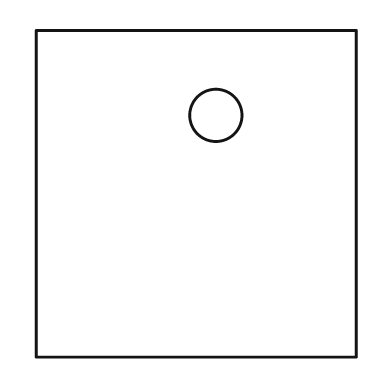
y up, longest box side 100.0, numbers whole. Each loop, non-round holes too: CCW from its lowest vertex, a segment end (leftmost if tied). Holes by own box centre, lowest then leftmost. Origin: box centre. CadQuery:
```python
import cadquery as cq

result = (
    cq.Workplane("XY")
    .moveTo(-49.0, -50.0)
    .lineTo(49.0, -50.0)
    .lineTo(49.0, 50.0)
    .lineTo(-49.0, 50.0)
    .close()
    .moveTo(6.0, 24.0)
    .circle(8.0)
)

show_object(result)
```